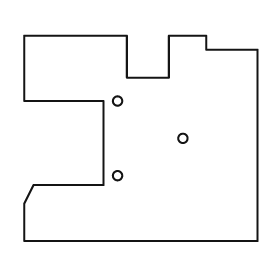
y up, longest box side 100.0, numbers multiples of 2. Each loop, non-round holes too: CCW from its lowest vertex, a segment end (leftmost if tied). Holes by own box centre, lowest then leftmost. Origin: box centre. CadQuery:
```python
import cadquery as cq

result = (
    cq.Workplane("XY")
    .moveTo(-50.0, -44.0)
    .lineTo(50.0, -44.0)
    .lineTo(50.0, 38.0)
    .lineTo(28.0, 38.0)
    .lineTo(28.0, 44.0)
    .lineTo(12.0, 44.0)
    .lineTo(12.0, 26.0)
    .lineTo(-6.0, 26.0)
    .lineTo(-6.0, 44.0)
    .lineTo(-50.0, 44.0)
    .lineTo(-50.0, 16.0)
    .lineTo(-16.0, 16.0)
    .lineTo(-16.0, -20.0)
    .lineTo(-46.0, -20.0)
    .lineTo(-50.0, -28.0)
    .close()
    .moveTo(-10.0, -16.0)
    .circle(2.0)
    .moveTo(18.0, 0.0)
    .circle(2.0)
    .moveTo(-10.0, 16.0)
    .circle(2.0)
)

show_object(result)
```